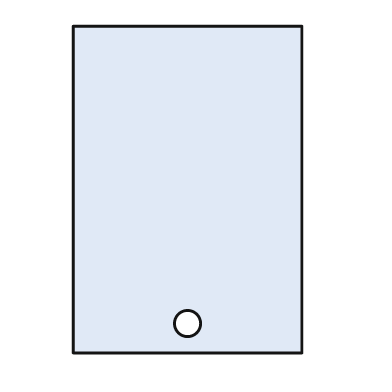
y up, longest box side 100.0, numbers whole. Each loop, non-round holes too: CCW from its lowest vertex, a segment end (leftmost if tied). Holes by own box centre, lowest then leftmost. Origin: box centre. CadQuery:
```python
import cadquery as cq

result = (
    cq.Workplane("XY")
    .moveTo(-35.0, -50.0)
    .lineTo(35.0, -50.0)
    .lineTo(35.0, 50.0)
    .lineTo(-35.0, 50.0)
    .close()
    .moveTo(0.0, -41.0)
    .circle(4.0)
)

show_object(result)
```